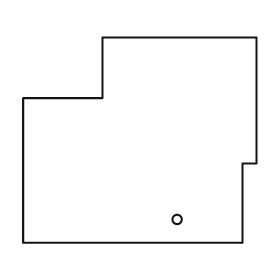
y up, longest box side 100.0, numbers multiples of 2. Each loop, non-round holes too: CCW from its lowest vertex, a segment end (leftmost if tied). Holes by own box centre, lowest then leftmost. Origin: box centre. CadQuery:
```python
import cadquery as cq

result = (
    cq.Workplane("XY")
    .moveTo(-50.0, -44.0)
    .lineTo(44.0, -44.0)
    .lineTo(44.0, -10.0)
    .lineTo(50.0, -10.0)
    .lineTo(50.0, 44.0)
    .lineTo(-16.0, 44.0)
    .lineTo(-16.0, 18.0)
    .lineTo(-50.0, 18.0)
    .close()
    .moveTo(16.0, -34.0)
    .circle(2.0)
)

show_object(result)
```